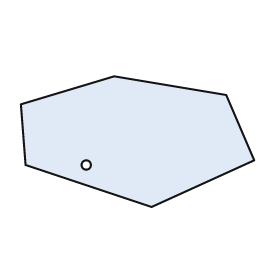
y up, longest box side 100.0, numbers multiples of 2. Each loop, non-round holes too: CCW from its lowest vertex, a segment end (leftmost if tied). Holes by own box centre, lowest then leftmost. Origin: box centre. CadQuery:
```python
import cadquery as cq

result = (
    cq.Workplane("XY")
    .moveTo(6.0, -28.0)
    .lineTo(50.0, -8.0)
    .lineTo(38.0, 20.0)
    .lineTo(-10.0, 28.0)
    .lineTo(-50.0, 16.0)
    .lineTo(-48.0, -10.0)
    .close()
    .moveTo(-22.0, -10.0)
    .circle(2.0)
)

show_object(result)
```